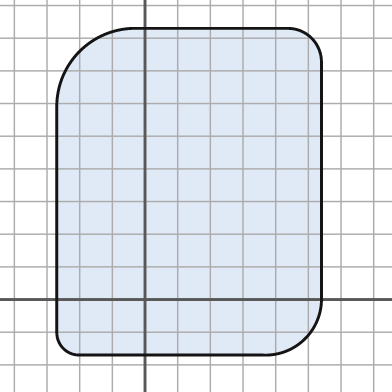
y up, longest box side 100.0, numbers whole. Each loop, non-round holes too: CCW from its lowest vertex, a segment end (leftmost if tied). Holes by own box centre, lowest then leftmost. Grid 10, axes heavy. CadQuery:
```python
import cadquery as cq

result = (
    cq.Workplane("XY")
    .moveTo(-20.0, -17.0)
    .lineTo(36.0, -17.0)
    .threePointArc((49.0, -12.0), (54.0, 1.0))
    .lineTo(54.0, 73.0)
    .threePointArc((51.0, 80.0), (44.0, 83.0))
    .lineTo(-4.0, 83.0)
    .threePointArc((-20.0, 76.0), (-27.0, 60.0))
    .lineTo(-27.0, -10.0)
    .threePointArc((-25.0, -15.0), (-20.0, -17.0))
    .close()
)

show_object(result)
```